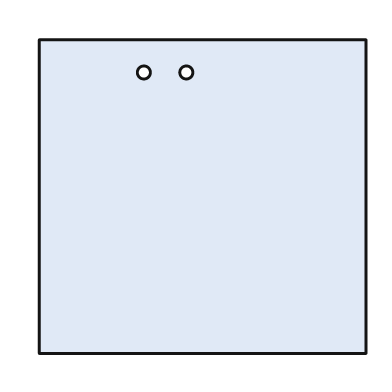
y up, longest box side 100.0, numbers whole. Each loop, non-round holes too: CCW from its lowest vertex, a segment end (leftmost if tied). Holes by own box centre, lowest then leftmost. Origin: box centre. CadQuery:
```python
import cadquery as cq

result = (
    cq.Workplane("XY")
    .moveTo(-50.0, -48.0)
    .lineTo(50.0, -48.0)
    .lineTo(50.0, 48.0)
    .lineTo(-50.0, 48.0)
    .close()
    .moveTo(-18.0, 38.0)
    .circle(2.0)
    .moveTo(-5.0, 38.0)
    .circle(2.0)
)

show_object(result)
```